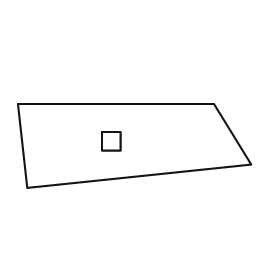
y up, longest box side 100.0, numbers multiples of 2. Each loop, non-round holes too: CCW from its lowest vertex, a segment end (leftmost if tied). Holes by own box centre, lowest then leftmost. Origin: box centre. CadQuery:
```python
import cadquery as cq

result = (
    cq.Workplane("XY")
    .moveTo(-46.0, -18.0)
    .lineTo(50.0, -8.0)
    .lineTo(34.0, 18.0)
    .lineTo(-50.0, 18.0)
    .close()
    .moveTo(-14.0, -2.0)
    .lineTo(-6.0, -2.0)
    .lineTo(-6.0, 6.0)
    .lineTo(-14.0, 6.0)
    .close()
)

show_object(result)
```